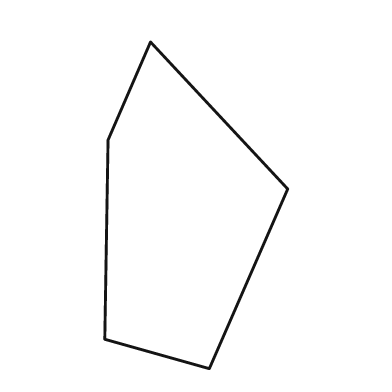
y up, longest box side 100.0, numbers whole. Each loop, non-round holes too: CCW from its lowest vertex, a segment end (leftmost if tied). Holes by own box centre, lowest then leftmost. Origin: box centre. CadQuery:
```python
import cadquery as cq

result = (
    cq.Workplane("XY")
    .moveTo(4.0, -50.0)
    .lineTo(28.0, 5.0)
    .lineTo(-14.0, 50.0)
    .lineTo(-27.0, 20.0)
    .lineTo(-28.0, -41.0)
    .close()
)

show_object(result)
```